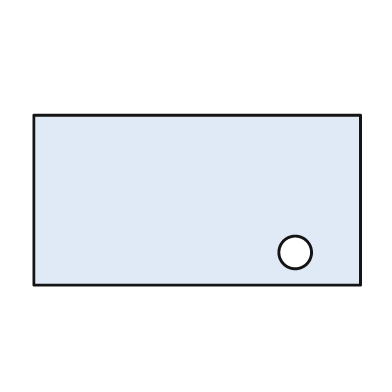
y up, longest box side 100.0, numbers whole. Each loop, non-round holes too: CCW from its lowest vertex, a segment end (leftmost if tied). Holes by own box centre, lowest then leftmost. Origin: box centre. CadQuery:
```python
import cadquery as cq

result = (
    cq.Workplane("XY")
    .moveTo(-50.0, -26.0)
    .lineTo(50.0, -26.0)
    .lineTo(50.0, 26.0)
    .lineTo(-50.0, 26.0)
    .close()
    .moveTo(30.0, -16.0)
    .circle(5.0)
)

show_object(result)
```